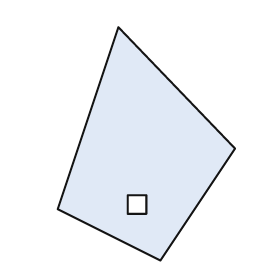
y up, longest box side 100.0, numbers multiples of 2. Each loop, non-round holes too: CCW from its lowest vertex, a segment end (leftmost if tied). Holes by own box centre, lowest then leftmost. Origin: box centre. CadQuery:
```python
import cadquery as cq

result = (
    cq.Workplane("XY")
    .moveTo(6.0, -50.0)
    .lineTo(38.0, -2.0)
    .lineTo(-12.0, 50.0)
    .lineTo(-38.0, -28.0)
    .close()
    .moveTo(-8.0, -30.0)
    .lineTo(0.0, -30.0)
    .lineTo(0.0, -22.0)
    .lineTo(-8.0, -22.0)
    .close()
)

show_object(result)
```